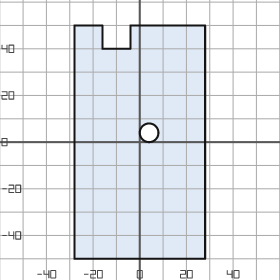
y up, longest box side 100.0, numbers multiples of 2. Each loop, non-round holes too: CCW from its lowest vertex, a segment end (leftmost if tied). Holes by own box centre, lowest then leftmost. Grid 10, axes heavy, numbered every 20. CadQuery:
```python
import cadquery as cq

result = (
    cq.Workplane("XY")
    .moveTo(-28.0, -50.0)
    .lineTo(28.0, -50.0)
    .lineTo(28.0, 50.0)
    .lineTo(-4.0, 50.0)
    .lineTo(-4.0, 40.0)
    .lineTo(-16.0, 40.0)
    .lineTo(-16.0, 50.0)
    .lineTo(-28.0, 50.0)
    .close()
    .moveTo(4.0, 4.0)
    .circle(4.0)
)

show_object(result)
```